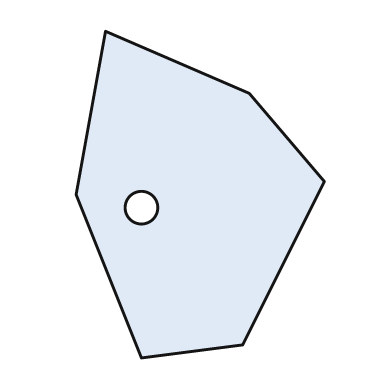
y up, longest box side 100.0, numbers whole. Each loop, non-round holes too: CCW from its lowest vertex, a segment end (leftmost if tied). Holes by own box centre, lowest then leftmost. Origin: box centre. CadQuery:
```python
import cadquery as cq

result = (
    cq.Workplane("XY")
    .moveTo(-18.0, -50.0)
    .lineTo(13.0, -46.0)
    .lineTo(38.0, 4.0)
    .lineTo(15.0, 31.0)
    .lineTo(-29.0, 50.0)
    .lineTo(-38.0, 0.0)
    .close()
    .moveTo(-18.0, -4.0)
    .circle(5.0)
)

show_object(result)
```